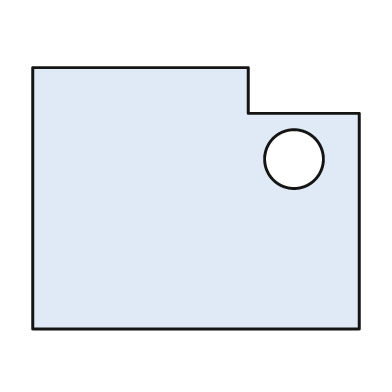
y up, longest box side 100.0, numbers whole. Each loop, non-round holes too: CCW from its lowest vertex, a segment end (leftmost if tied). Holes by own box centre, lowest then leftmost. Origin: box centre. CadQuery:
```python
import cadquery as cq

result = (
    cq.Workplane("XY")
    .moveTo(-50.0, -40.0)
    .lineTo(50.0, -40.0)
    .lineTo(50.0, 26.0)
    .lineTo(16.0, 26.0)
    .lineTo(16.0, 40.0)
    .lineTo(-50.0, 40.0)
    .close()
    .moveTo(30.0, 12.0)
    .circle(9.0)
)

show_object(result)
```